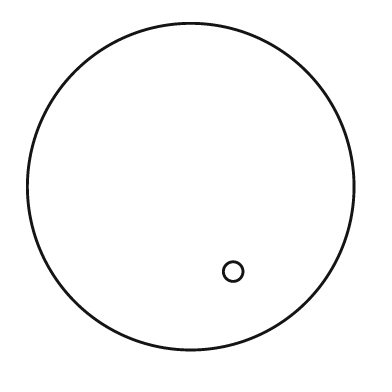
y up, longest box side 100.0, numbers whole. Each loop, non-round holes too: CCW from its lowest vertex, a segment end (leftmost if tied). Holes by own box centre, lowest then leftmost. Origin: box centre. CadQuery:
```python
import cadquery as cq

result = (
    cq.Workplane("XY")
    .moveTo(0.0, 0.0)
    .circle(50.0)
    .moveTo(13.0, -26.0)
    .circle(3.0)
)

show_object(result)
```